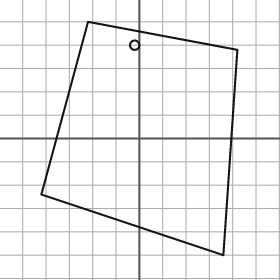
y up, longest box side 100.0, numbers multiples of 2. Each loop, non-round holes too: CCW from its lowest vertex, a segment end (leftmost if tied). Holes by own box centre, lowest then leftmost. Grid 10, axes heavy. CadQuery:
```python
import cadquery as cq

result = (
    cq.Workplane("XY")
    .moveTo(36.0, -50.0)
    .lineTo(42.0, 38.0)
    .lineTo(-22.0, 50.0)
    .lineTo(-42.0, -24.0)
    .close()
    .moveTo(-2.0, 40.0)
    .circle(2.0)
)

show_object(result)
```